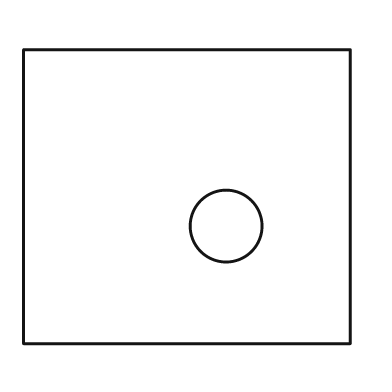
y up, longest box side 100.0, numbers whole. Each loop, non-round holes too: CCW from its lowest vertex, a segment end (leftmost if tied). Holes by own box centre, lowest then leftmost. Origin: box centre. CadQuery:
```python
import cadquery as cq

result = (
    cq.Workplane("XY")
    .moveTo(-50.0, -45.0)
    .lineTo(50.0, -45.0)
    .lineTo(50.0, 45.0)
    .lineTo(-50.0, 45.0)
    .close()
    .moveTo(12.0, -9.0)
    .circle(11.0)
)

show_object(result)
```